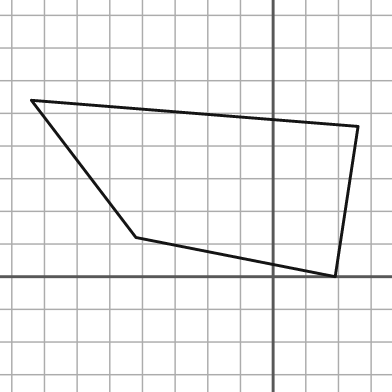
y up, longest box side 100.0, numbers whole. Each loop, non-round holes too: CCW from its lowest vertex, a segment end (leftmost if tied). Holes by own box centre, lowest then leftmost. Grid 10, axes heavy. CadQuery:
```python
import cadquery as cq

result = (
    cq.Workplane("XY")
    .moveTo(19.0, 0.0)
    .lineTo(26.0, 46.0)
    .lineTo(-74.0, 54.0)
    .lineTo(-42.0, 12.0)
    .close()
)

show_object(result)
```